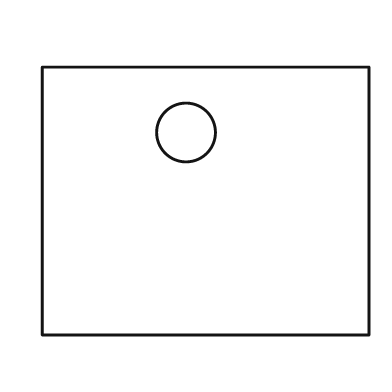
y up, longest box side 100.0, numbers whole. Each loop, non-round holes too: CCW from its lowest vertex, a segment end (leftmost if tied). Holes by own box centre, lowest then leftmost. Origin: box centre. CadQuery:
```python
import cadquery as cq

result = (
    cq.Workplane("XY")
    .moveTo(-50.0, -41.0)
    .lineTo(50.0, -41.0)
    .lineTo(50.0, 41.0)
    .lineTo(-50.0, 41.0)
    .close()
    .moveTo(-6.0, 21.0)
    .circle(9.0)
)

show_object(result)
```